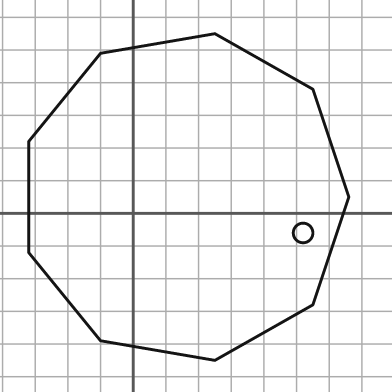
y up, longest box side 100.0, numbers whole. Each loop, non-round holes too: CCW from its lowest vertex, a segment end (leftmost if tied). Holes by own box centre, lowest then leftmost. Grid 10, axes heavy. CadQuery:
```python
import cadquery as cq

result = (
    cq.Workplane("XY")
    .moveTo(25.0, -45.0)
    .lineTo(55.0, -28.0)
    .lineTo(66.0, 5.0)
    .lineTo(55.0, 38.0)
    .lineTo(25.0, 55.0)
    .lineTo(-10.0, 49.0)
    .lineTo(-32.0, 22.0)
    .lineTo(-32.0, -12.0)
    .lineTo(-10.0, -39.0)
    .close()
    .moveTo(52.0, -6.0)
    .circle(3.0)
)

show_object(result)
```